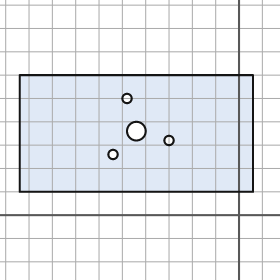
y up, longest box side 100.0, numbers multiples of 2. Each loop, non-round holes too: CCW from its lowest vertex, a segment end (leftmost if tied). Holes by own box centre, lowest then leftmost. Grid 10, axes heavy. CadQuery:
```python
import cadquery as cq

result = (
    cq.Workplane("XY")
    .moveTo(-94.0, 10.0)
    .lineTo(6.0, 10.0)
    .lineTo(6.0, 60.0)
    .lineTo(-94.0, 60.0)
    .close()
    .moveTo(-54.0, 26.0)
    .circle(2.0)
    .moveTo(-30.0, 32.0)
    .circle(2.0)
    .moveTo(-44.0, 36.0)
    .circle(4.0)
    .moveTo(-48.0, 50.0)
    .circle(2.0)
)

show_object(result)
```